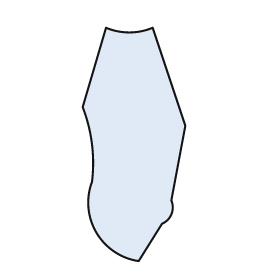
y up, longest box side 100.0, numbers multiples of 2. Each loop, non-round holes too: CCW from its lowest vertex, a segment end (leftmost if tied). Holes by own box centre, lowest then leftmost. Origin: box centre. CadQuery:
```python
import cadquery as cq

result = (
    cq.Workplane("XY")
    .moveTo(2.0, -50.0)
    .lineTo(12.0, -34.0)
    .threePointArc((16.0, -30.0), (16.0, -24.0))
    .lineTo(22.0, 8.0)
    .lineTo(8.0, 50.0)
    .threePointArc((-2.0, 48.0), (-12.0, 50.0))
    .lineTo(-22.0, 16.0)
    .threePointArc((-18.0, 0.0), (-18.0, -16.0))
    .threePointArc((-16.0, -38.0), (2.0, -50.0))
    .close()
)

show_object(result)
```